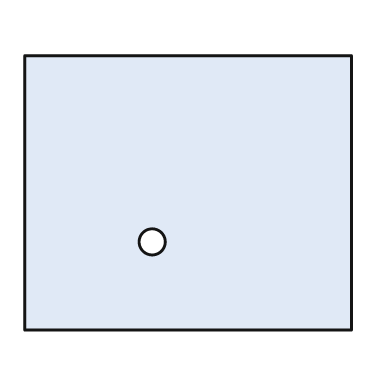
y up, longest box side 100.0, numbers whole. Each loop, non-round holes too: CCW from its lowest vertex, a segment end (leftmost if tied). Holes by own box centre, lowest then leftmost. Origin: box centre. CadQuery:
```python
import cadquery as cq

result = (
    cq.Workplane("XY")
    .moveTo(-50.0, -42.0)
    .lineTo(50.0, -42.0)
    .lineTo(50.0, 42.0)
    .lineTo(-50.0, 42.0)
    .close()
    .moveTo(-11.0, -15.0)
    .circle(4.0)
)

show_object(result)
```